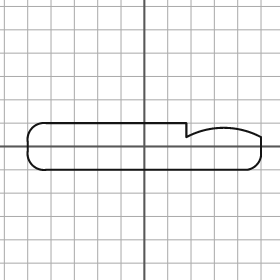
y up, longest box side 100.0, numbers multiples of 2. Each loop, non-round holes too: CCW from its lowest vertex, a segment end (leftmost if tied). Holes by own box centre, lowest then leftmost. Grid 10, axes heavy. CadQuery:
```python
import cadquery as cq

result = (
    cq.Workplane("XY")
    .moveTo(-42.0, -10.0)
    .lineTo(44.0, -10.0)
    .threePointArc((48.0, -8.0), (50.0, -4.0))
    .lineTo(50.0, 4.0)
    .threePointArc((34.0, 8.0), (18.0, 4.0))
    .lineTo(18.0, 10.0)
    .lineTo(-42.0, 10.0)
    .threePointArc((-48.0, 8.0), (-50.0, 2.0))
    .lineTo(-50.0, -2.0)
    .threePointArc((-48.0, -8.0), (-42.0, -10.0))
    .close()
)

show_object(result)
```